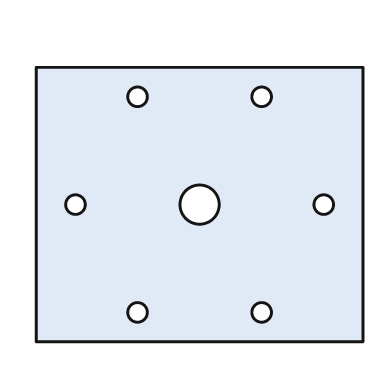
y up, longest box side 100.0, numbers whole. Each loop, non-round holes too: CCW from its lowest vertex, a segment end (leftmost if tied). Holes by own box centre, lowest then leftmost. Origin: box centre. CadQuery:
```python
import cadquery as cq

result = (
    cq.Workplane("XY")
    .moveTo(-50.0, -42.0)
    .lineTo(50.0, -42.0)
    .lineTo(50.0, 42.0)
    .lineTo(-50.0, 42.0)
    .close()
    .moveTo(-19.0, -33.0)
    .circle(3.0)
    .moveTo(19.0, -33.0)
    .circle(3.0)
    .moveTo(-38.0, 0.0)
    .circle(3.0)
    .moveTo(0.0, 0.0)
    .circle(6.0)
    .moveTo(38.0, 0.0)
    .circle(3.0)
    .moveTo(-19.0, 33.0)
    .circle(3.0)
    .moveTo(19.0, 33.0)
    .circle(3.0)
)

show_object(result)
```